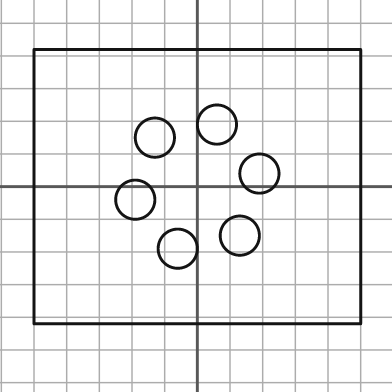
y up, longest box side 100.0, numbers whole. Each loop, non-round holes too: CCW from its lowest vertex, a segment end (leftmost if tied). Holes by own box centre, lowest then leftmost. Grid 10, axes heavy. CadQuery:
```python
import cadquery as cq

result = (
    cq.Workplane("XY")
    .moveTo(-50.0, -42.0)
    .lineTo(50.0, -42.0)
    .lineTo(50.0, 42.0)
    .lineTo(-50.0, 42.0)
    .close()
    .moveTo(-6.0, -19.0)
    .circle(6.0)
    .moveTo(13.0, -15.0)
    .circle(6.0)
    .moveTo(-19.0, -4.0)
    .circle(6.0)
    .moveTo(19.0, 4.0)
    .circle(6.0)
    .moveTo(-13.0, 15.0)
    .circle(6.0)
    .moveTo(6.0, 19.0)
    .circle(6.0)
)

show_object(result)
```